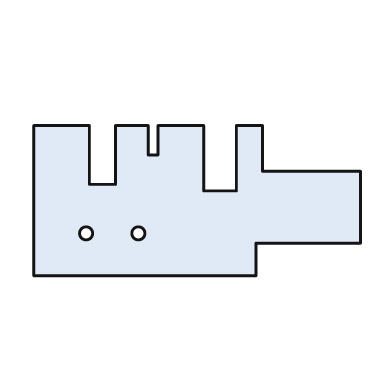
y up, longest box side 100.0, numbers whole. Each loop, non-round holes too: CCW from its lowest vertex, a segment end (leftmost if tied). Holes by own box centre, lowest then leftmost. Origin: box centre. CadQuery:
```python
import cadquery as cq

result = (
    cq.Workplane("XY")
    .moveTo(-50.0, -23.0)
    .lineTo(18.0, -23.0)
    .lineTo(18.0, -13.0)
    .lineTo(50.0, -13.0)
    .lineTo(50.0, 9.0)
    .lineTo(20.0, 9.0)
    .lineTo(20.0, 23.0)
    .lineTo(12.0, 23.0)
    .lineTo(12.0, 3.0)
    .lineTo(2.0, 3.0)
    .lineTo(2.0, 23.0)
    .lineTo(-12.0, 23.0)
    .lineTo(-12.0, 14.0)
    .lineTo(-15.0, 14.0)
    .lineTo(-15.0, 23.0)
    .lineTo(-25.0, 23.0)
    .lineTo(-25.0, 5.0)
    .lineTo(-33.0, 5.0)
    .lineTo(-33.0, 23.0)
    .lineTo(-50.0, 23.0)
    .close()
    .moveTo(-34.0, -10.0)
    .circle(2.0)
    .moveTo(-18.0, -10.0)
    .circle(2.0)
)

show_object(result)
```